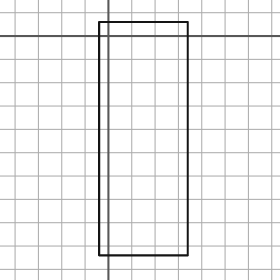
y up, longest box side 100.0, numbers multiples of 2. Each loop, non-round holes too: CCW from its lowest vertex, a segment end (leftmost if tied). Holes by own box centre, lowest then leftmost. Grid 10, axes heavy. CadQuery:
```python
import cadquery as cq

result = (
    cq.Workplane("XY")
    .moveTo(-4.0, -94.0)
    .lineTo(34.0, -94.0)
    .lineTo(34.0, 6.0)
    .lineTo(-4.0, 6.0)
    .close()
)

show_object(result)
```